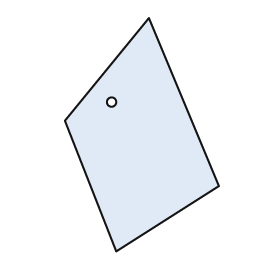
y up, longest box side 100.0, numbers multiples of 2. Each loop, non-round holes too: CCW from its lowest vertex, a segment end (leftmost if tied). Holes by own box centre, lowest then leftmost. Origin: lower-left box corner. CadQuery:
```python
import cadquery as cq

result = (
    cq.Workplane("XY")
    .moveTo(22.0, 0.0)
    .lineTo(66.0, 28.0)
    .lineTo(36.0, 100.0)
    .lineTo(0.0, 56.0)
    .close()
    .moveTo(20.0, 64.0)
    .circle(2.0)
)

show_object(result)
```